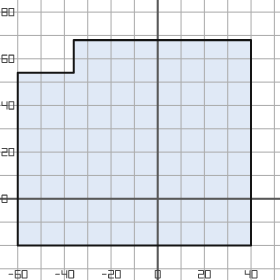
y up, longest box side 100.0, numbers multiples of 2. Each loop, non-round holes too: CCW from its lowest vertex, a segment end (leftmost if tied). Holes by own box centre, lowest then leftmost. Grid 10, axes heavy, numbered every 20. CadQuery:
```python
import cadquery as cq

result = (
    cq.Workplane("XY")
    .moveTo(-60.0, -20.0)
    .lineTo(40.0, -20.0)
    .lineTo(40.0, 68.0)
    .lineTo(-36.0, 68.0)
    .lineTo(-36.0, 54.0)
    .lineTo(-60.0, 54.0)
    .close()
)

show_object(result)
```